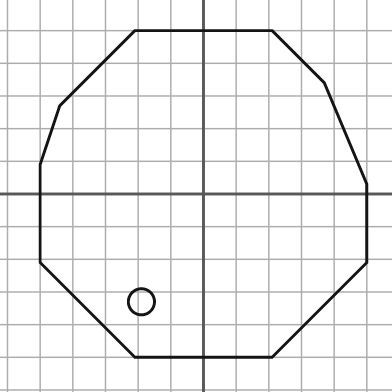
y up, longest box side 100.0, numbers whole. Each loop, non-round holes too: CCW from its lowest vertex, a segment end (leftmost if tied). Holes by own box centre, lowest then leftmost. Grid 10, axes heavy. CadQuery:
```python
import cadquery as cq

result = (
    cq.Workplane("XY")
    .moveTo(-21.0, -50.0)
    .lineTo(21.0, -50.0)
    .lineTo(50.0, -21.0)
    .lineTo(50.0, 3.0)
    .lineTo(37.0, 34.0)
    .lineTo(21.0, 50.0)
    .lineTo(-21.0, 50.0)
    .lineTo(-44.0, 27.0)
    .lineTo(-50.0, 9.0)
    .lineTo(-50.0, -21.0)
    .close()
    .moveTo(-19.0, -33.0)
    .circle(4.0)
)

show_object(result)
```